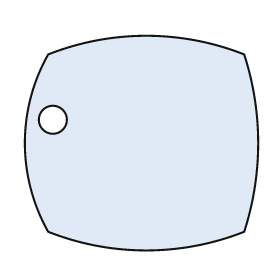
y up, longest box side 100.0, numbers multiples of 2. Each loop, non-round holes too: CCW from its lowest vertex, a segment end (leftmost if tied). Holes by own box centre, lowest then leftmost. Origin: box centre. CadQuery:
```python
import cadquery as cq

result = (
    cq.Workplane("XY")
    .moveTo(-40.0, -38.0)
    .threePointArc((2.0, -46.0), (44.0, -38.0))
    .threePointArc((50.0, 0.0), (44.0, 38.0))
    .threePointArc((2.0, 46.0), (-40.0, 38.0))
    .threePointArc((-50.0, 0.0), (-40.0, -38.0))
    .close()
    .moveTo(-38.0, 10.0)
    .circle(6.0)
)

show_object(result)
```